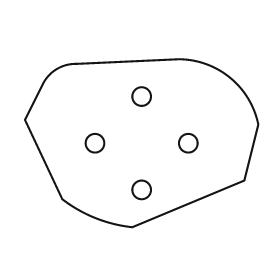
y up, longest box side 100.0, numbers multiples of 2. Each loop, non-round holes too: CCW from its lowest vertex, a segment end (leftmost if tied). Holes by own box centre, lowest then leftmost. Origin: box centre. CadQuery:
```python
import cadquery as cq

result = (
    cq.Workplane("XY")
    .moveTo(-4.0, -36.0)
    .lineTo(44.0, -16.0)
    .lineTo(50.0, 8.0)
    .threePointArc((38.0, 28.0), (16.0, 36.0))
    .lineTo(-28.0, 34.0)
    .threePointArc((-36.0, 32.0), (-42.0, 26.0))
    .lineTo(-50.0, 10.0)
    .lineTo(-34.0, -24.0)
    .threePointArc((-20.0, -32.0), (-4.0, -36.0))
    .close()
    .moveTo(0.0, -20.0)
    .circle(4.0)
    .moveTo(-20.0, 0.0)
    .circle(4.0)
    .moveTo(20.0, 0.0)
    .circle(4.0)
    .moveTo(0.0, 20.0)
    .circle(4.0)
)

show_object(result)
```